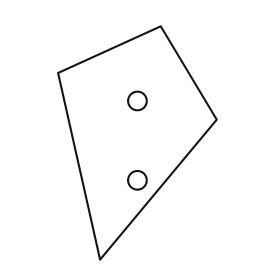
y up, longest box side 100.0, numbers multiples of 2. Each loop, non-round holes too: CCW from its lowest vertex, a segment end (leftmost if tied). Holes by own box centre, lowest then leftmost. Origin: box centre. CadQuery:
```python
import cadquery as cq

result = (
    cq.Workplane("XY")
    .moveTo(-16.0, -50.0)
    .lineTo(34.0, 10.0)
    .lineTo(10.0, 50.0)
    .lineTo(-34.0, 30.0)
    .close()
    .moveTo(0.0, -16.0)
    .circle(4.0)
    .moveTo(0.0, 18.0)
    .circle(4.0)
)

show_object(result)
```